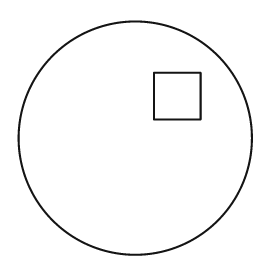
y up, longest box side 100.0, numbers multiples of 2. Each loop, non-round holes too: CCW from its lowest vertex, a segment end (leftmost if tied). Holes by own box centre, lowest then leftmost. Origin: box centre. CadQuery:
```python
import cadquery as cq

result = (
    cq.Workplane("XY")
    .moveTo(0.0, 0.0)
    .circle(50.0)
    .moveTo(8.0, 8.0)
    .lineTo(28.0, 8.0)
    .lineTo(28.0, 28.0)
    .lineTo(8.0, 28.0)
    .close()
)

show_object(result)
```